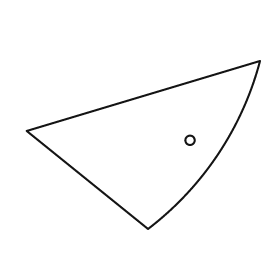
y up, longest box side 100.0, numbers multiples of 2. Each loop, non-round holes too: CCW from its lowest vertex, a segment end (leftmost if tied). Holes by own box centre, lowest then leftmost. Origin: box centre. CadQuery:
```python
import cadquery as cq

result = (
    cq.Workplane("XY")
    .moveTo(2.0, -36.0)
    .threePointArc((32.0, -4.0), (50.0, 36.0))
    .lineTo(-50.0, 6.0)
    .close()
    .moveTo(20.0, 2.0)
    .circle(2.0)
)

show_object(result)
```